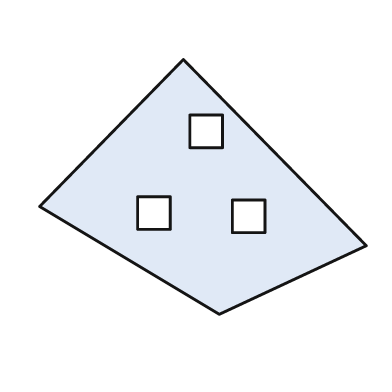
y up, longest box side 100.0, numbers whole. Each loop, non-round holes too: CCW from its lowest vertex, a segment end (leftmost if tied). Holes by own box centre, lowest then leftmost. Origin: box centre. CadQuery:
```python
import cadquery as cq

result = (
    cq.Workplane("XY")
    .moveTo(5.0, -39.0)
    .lineTo(50.0, -18.0)
    .lineTo(-6.0, 39.0)
    .lineTo(-50.0, -6.0)
    .close()
    .moveTo(9.0, -14.0)
    .lineTo(19.0, -14.0)
    .lineTo(19.0, -4.0)
    .lineTo(9.0, -4.0)
    .close()
    .moveTo(-20.0, -13.0)
    .lineTo(-10.0, -13.0)
    .lineTo(-10.0, -3.0)
    .lineTo(-20.0, -3.0)
    .close()
    .moveTo(-4.0, 12.0)
    .lineTo(6.0, 12.0)
    .lineTo(6.0, 22.0)
    .lineTo(-4.0, 22.0)
    .close()
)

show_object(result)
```